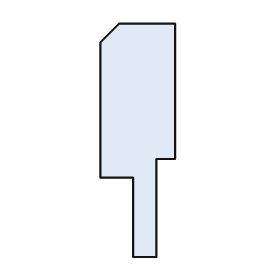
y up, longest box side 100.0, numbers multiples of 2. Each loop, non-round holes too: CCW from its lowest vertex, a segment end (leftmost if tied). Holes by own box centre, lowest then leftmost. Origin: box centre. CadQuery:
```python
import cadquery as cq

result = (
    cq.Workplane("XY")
    .moveTo(-2.0, -50.0)
    .lineTo(8.0, -50.0)
    .lineTo(8.0, -8.0)
    .lineTo(16.0, -8.0)
    .lineTo(16.0, 50.0)
    .lineTo(-8.0, 50.0)
    .lineTo(-16.0, 42.0)
    .lineTo(-16.0, -16.0)
    .lineTo(-2.0, -16.0)
    .close()
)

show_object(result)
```